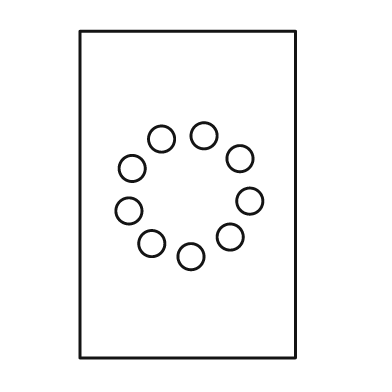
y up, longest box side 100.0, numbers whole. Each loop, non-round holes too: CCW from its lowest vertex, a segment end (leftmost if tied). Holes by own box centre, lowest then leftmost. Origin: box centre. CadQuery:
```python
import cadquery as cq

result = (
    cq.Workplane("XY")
    .moveTo(-33.0, -50.0)
    .lineTo(33.0, -50.0)
    .lineTo(33.0, 50.0)
    .lineTo(-33.0, 50.0)
    .close()
    .moveTo(1.0, -19.0)
    .circle(4.0)
    .moveTo(-11.0, -15.0)
    .circle(4.0)
    .moveTo(13.0, -13.0)
    .circle(4.0)
    .moveTo(-18.0, -5.0)
    .circle(4.0)
    .moveTo(19.0, -2.0)
    .circle(4.0)
    .moveTo(-17.0, 8.0)
    .circle(4.0)
    .moveTo(16.0, 11.0)
    .circle(4.0)
    .moveTo(-8.0, 17.0)
    .circle(4.0)
    .moveTo(5.0, 18.0)
    .circle(4.0)
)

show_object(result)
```